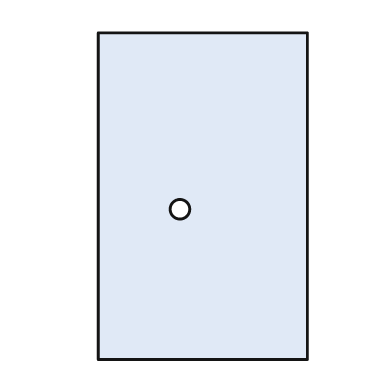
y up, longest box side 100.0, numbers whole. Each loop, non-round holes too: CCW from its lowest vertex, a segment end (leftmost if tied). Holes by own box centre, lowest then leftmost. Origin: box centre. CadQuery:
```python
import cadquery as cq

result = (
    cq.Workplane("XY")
    .moveTo(-32.0, -50.0)
    .lineTo(32.0, -50.0)
    .lineTo(32.0, 50.0)
    .lineTo(-32.0, 50.0)
    .close()
    .moveTo(-7.0, -4.0)
    .circle(3.0)
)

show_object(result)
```